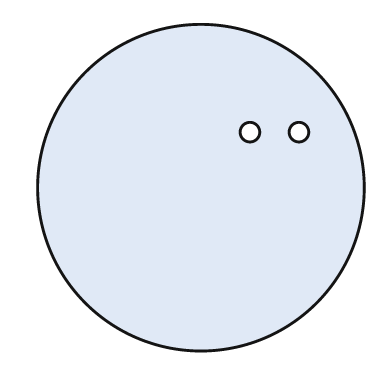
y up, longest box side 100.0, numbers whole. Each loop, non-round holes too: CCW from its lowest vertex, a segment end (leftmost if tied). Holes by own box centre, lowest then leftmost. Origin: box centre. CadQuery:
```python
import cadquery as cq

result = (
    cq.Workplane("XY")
    .moveTo(0.0, 0.0)
    .circle(50.0)
    .moveTo(15.0, 17.0)
    .circle(3.0)
    .moveTo(30.0, 17.0)
    .circle(3.0)
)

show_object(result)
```